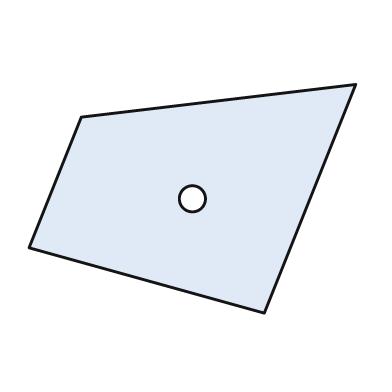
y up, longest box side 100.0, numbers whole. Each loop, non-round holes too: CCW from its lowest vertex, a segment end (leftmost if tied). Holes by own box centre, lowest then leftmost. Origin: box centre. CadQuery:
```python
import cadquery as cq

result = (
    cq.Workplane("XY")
    .moveTo(22.0, -35.0)
    .lineTo(50.0, 35.0)
    .lineTo(-34.0, 25.0)
    .lineTo(-50.0, -15.0)
    .close()
    .moveTo(0.0, 0.0)
    .circle(4.0)
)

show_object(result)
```